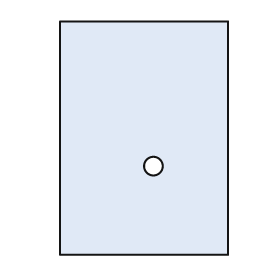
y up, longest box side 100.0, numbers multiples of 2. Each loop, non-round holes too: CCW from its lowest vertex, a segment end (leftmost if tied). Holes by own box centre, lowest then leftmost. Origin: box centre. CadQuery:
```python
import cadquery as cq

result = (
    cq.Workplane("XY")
    .moveTo(-36.0, -50.0)
    .lineTo(36.0, -50.0)
    .lineTo(36.0, 50.0)
    .lineTo(-36.0, 50.0)
    .close()
    .moveTo(4.0, -12.0)
    .circle(4.0)
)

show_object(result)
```